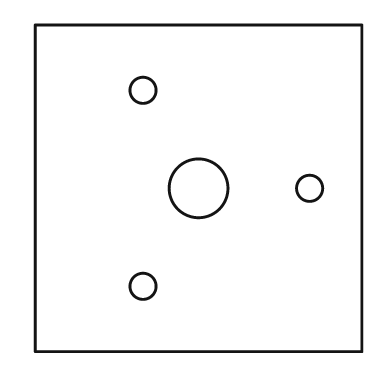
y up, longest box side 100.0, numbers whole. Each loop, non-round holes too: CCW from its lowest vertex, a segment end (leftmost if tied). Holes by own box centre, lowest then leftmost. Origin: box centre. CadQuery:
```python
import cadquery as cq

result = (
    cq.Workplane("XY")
    .moveTo(-50.0, -50.0)
    .lineTo(50.0, -50.0)
    .lineTo(50.0, 50.0)
    .lineTo(-50.0, 50.0)
    .close()
    .moveTo(-17.0, -30.0)
    .circle(4.0)
    .moveTo(0.0, 0.0)
    .circle(9.0)
    .moveTo(34.0, 0.0)
    .circle(4.0)
    .moveTo(-17.0, 30.0)
    .circle(4.0)
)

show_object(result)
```